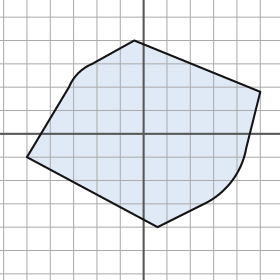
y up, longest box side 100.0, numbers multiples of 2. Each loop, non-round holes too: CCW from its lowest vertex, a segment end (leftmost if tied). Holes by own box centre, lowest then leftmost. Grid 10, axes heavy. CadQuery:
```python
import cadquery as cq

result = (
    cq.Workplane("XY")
    .moveTo(6.0, -40.0)
    .lineTo(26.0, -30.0)
    .threePointArc((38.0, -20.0), (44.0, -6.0))
    .lineTo(50.0, 18.0)
    .lineTo(-4.0, 40.0)
    .lineTo(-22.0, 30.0)
    .threePointArc((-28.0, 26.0), (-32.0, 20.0))
    .lineTo(-50.0, -10.0)
    .close()
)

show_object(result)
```